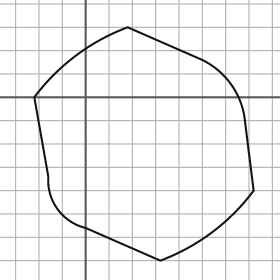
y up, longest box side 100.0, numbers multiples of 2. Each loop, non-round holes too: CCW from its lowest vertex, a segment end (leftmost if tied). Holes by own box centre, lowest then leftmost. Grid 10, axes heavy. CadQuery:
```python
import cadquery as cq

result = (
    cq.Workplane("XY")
    .moveTo(32.0, -70.0)
    .threePointArc((54.0, -58.0), (72.0, -40.0))
    .lineTo(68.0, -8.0)
    .threePointArc((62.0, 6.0), (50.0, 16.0))
    .lineTo(18.0, 30.0)
    .threePointArc((-4.0, 18.0), (-22.0, 0.0))
    .lineTo(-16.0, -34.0)
    .threePointArc((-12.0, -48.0), (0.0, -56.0))
    .close()
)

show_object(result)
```